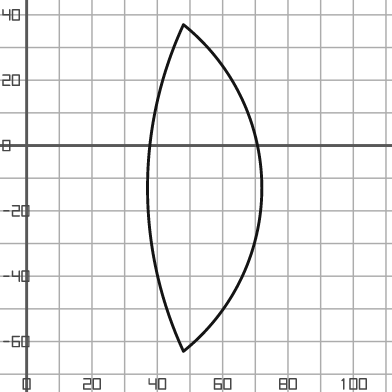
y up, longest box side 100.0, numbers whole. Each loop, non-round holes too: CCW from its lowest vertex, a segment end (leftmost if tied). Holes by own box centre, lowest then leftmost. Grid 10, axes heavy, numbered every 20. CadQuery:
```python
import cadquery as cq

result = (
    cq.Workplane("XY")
    .moveTo(48.0, -63.0)
    .threePointArc((72.0, -13.0), (48.0, 37.0))
    .threePointArc((37.0, -13.0), (48.0, -63.0))
    .close()
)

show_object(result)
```